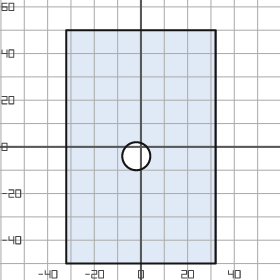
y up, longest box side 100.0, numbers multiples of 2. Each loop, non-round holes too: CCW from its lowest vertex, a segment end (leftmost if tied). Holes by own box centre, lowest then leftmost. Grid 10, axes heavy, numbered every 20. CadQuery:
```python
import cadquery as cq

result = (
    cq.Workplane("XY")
    .moveTo(-32.0, -50.0)
    .lineTo(32.0, -50.0)
    .lineTo(32.0, 50.0)
    .lineTo(-32.0, 50.0)
    .close()
    .moveTo(-2.0, -4.0)
    .circle(6.0)
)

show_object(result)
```